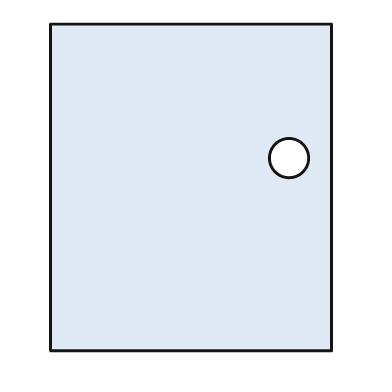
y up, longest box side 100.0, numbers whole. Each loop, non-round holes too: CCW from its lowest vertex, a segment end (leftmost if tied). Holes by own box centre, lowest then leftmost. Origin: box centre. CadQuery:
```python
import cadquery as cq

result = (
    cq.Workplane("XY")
    .moveTo(-43.0, -50.0)
    .lineTo(43.0, -50.0)
    .lineTo(43.0, 50.0)
    .lineTo(-43.0, 50.0)
    .close()
    .moveTo(30.0, 9.0)
    .circle(6.0)
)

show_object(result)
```